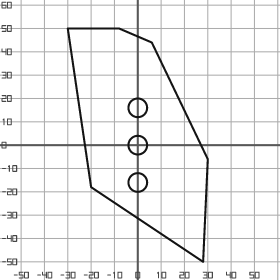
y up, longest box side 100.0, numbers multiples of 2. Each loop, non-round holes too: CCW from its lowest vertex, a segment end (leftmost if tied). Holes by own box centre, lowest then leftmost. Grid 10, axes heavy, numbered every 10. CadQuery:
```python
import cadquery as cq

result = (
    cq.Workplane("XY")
    .moveTo(28.0, -50.0)
    .lineTo(30.0, -6.0)
    .lineTo(6.0, 44.0)
    .lineTo(-8.0, 50.0)
    .lineTo(-30.0, 50.0)
    .lineTo(-20.0, -18.0)
    .close()
    .moveTo(0.0, -16.0)
    .circle(4.0)
    .moveTo(0.0, 0.0)
    .circle(4.0)
    .moveTo(0.0, 16.0)
    .circle(4.0)
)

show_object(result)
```